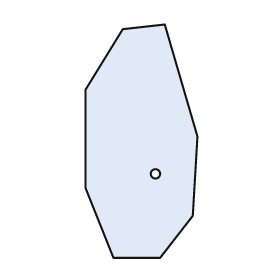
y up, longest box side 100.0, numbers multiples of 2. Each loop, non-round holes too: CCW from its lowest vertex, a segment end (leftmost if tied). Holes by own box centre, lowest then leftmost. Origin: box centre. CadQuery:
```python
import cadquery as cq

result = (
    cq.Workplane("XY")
    .moveTo(-12.0, -50.0)
    .lineTo(8.0, -50.0)
    .lineTo(22.0, -32.0)
    .lineTo(24.0, 2.0)
    .lineTo(10.0, 50.0)
    .lineTo(-8.0, 48.0)
    .lineTo(-24.0, 22.0)
    .lineTo(-24.0, -20.0)
    .close()
    .moveTo(6.0, -14.0)
    .circle(2.0)
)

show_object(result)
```